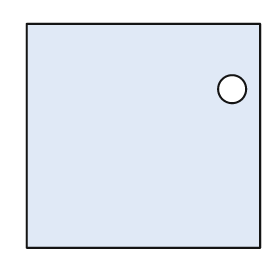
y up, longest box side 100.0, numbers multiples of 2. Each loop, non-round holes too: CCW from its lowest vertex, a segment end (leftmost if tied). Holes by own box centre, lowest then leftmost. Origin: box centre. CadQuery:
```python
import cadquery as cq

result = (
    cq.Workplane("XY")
    .moveTo(-50.0, -48.0)
    .lineTo(50.0, -48.0)
    .lineTo(50.0, 48.0)
    .lineTo(-50.0, 48.0)
    .close()
    .moveTo(38.0, 20.0)
    .circle(6.0)
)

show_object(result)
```